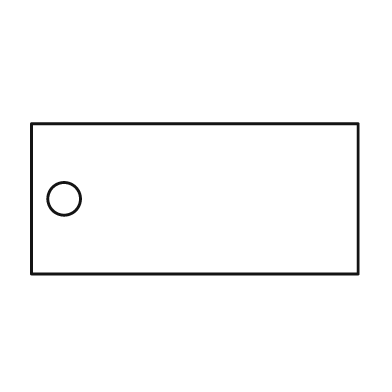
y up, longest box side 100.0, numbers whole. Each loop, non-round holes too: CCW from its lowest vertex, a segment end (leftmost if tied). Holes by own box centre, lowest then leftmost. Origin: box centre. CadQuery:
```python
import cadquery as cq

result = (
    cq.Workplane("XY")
    .moveTo(-50.0, -23.0)
    .lineTo(50.0, -23.0)
    .lineTo(50.0, 23.0)
    .lineTo(-50.0, 23.0)
    .close()
    .moveTo(-40.0, 0.0)
    .circle(5.0)
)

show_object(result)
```